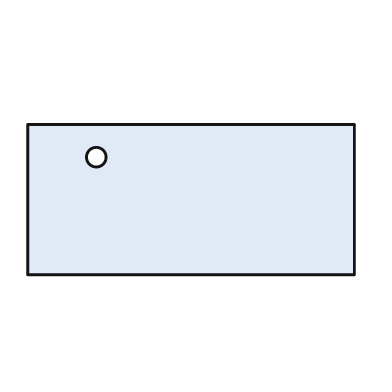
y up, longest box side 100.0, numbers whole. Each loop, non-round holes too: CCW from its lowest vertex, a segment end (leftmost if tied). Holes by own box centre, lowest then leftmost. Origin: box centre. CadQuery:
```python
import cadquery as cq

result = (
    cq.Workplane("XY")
    .moveTo(-50.0, -23.0)
    .lineTo(50.0, -23.0)
    .lineTo(50.0, 23.0)
    .lineTo(-50.0, 23.0)
    .close()
    .moveTo(-29.0, 13.0)
    .circle(3.0)
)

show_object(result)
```